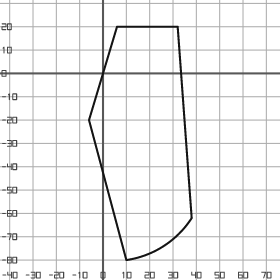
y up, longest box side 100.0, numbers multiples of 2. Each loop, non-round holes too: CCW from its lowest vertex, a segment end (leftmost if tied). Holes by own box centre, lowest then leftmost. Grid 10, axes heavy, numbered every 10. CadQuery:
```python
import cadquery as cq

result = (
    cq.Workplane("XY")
    .moveTo(10.0, -80.0)
    .threePointArc((26.0, -74.0), (38.0, -62.0))
    .lineTo(32.0, 20.0)
    .lineTo(6.0, 20.0)
    .lineTo(-6.0, -20.0)
    .close()
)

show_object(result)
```